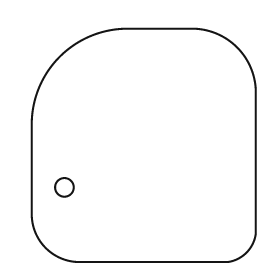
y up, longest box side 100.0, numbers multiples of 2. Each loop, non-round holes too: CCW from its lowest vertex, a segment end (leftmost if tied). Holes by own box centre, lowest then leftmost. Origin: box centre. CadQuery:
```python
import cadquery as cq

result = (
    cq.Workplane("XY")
    .moveTo(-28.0, -50.0)
    .lineTo(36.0, -50.0)
    .threePointArc((44.0, -46.0), (48.0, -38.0))
    .lineTo(48.0, 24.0)
    .threePointArc((40.0, 42.0), (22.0, 50.0))
    .lineTo(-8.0, 50.0)
    .threePointArc((-36.0, 38.0), (-48.0, 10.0))
    .lineTo(-48.0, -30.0)
    .threePointArc((-42.0, -44.0), (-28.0, -50.0))
    .close()
    .moveTo(-34.0, -18.0)
    .circle(4.0)
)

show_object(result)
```